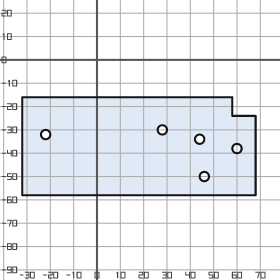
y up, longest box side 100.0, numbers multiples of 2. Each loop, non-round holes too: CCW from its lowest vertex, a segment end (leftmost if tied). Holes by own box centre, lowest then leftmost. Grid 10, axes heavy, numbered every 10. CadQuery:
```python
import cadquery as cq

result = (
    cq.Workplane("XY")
    .moveTo(-32.0, -58.0)
    .lineTo(68.0, -58.0)
    .lineTo(68.0, -24.0)
    .lineTo(58.0, -24.0)
    .lineTo(58.0, -16.0)
    .lineTo(-32.0, -16.0)
    .close()
    .moveTo(46.0, -50.0)
    .circle(2.0)
    .moveTo(60.0, -38.0)
    .circle(2.0)
    .moveTo(44.0, -34.0)
    .circle(2.0)
    .moveTo(-22.0, -32.0)
    .circle(2.0)
    .moveTo(28.0, -30.0)
    .circle(2.0)
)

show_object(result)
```